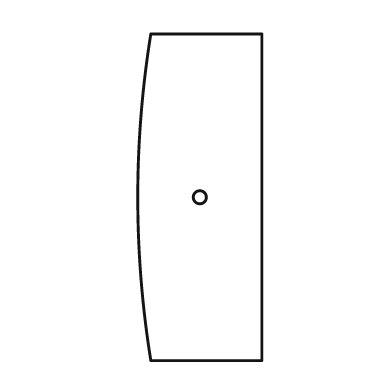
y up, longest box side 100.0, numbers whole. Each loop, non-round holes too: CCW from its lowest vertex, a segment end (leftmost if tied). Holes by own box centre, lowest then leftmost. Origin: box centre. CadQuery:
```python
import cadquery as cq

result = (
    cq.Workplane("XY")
    .moveTo(-15.0, -50.0)
    .lineTo(19.0, -50.0)
    .lineTo(19.0, 50.0)
    .lineTo(-15.0, 50.0)
    .threePointArc((-19.0, 0.0), (-15.0, -50.0))
    .close()
    .moveTo(0.0, 0.0)
    .circle(2.0)
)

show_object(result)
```